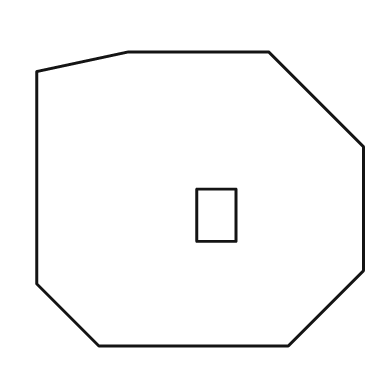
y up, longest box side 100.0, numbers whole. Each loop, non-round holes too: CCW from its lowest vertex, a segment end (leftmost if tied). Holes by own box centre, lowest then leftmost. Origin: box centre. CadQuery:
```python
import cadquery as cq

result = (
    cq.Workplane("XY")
    .moveTo(-31.0, -45.0)
    .lineTo(27.0, -45.0)
    .lineTo(50.0, -22.0)
    .lineTo(50.0, 16.0)
    .lineTo(21.0, 45.0)
    .lineTo(-22.0, 45.0)
    .lineTo(-50.0, 39.0)
    .lineTo(-50.0, -26.0)
    .close()
    .moveTo(-1.0, -13.0)
    .lineTo(11.0, -13.0)
    .lineTo(11.0, 3.0)
    .lineTo(-1.0, 3.0)
    .close()
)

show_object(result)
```